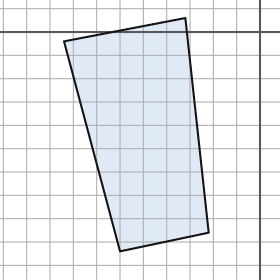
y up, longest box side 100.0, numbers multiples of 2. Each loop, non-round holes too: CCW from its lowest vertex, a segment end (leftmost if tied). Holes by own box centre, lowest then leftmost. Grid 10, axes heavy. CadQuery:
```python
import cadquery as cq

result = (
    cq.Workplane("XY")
    .moveTo(-60.0, -94.0)
    .lineTo(-22.0, -86.0)
    .lineTo(-32.0, 6.0)
    .lineTo(-84.0, -4.0)
    .close()
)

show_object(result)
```